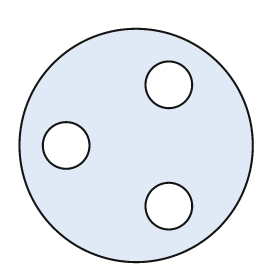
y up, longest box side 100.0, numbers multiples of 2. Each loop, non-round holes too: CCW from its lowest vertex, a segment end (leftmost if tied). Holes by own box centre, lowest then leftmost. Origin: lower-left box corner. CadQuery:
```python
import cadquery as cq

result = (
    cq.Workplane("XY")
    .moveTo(50.0, 50.0)
    .circle(50.0)
    .moveTo(64.0, 24.0)
    .circle(10.0)
    .moveTo(20.0, 50.0)
    .circle(10.0)
    .moveTo(64.0, 76.0)
    .circle(10.0)
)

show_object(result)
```